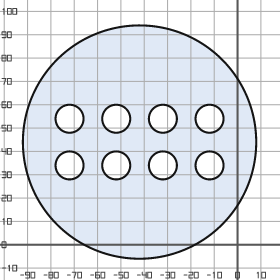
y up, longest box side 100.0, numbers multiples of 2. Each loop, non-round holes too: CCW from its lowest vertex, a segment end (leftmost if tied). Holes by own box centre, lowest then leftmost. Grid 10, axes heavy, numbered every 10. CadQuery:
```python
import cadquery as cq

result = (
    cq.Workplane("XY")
    .moveTo(-42.0, 44.0)
    .circle(50.0)
    .moveTo(-72.0, 34.0)
    .circle(6.0)
    .moveTo(-52.0, 34.0)
    .circle(6.0)
    .moveTo(-32.0, 34.0)
    .circle(6.0)
    .moveTo(-12.0, 34.0)
    .circle(6.0)
    .moveTo(-72.0, 54.0)
    .circle(6.0)
    .moveTo(-52.0, 54.0)
    .circle(6.0)
    .moveTo(-32.0, 54.0)
    .circle(6.0)
    .moveTo(-12.0, 54.0)
    .circle(6.0)
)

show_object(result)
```